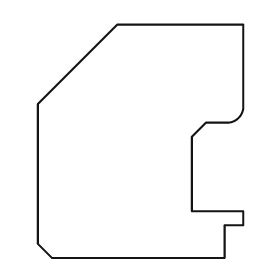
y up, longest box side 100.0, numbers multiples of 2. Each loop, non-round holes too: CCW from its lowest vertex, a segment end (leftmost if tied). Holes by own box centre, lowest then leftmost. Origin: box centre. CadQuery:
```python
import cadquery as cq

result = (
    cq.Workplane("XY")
    .moveTo(-38.0, -50.0)
    .lineTo(36.0, -50.0)
    .lineTo(36.0, -36.0)
    .lineTo(44.0, -36.0)
    .lineTo(44.0, -30.0)
    .lineTo(22.0, -30.0)
    .lineTo(22.0, 2.0)
    .lineTo(28.0, 8.0)
    .lineTo(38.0, 8.0)
    .threePointArc((42.0, 10.0), (44.0, 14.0))
    .lineTo(44.0, 50.0)
    .lineTo(-10.0, 50.0)
    .lineTo(-44.0, 16.0)
    .lineTo(-44.0, -44.0)
    .close()
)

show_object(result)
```